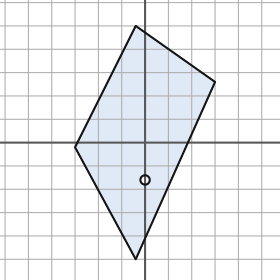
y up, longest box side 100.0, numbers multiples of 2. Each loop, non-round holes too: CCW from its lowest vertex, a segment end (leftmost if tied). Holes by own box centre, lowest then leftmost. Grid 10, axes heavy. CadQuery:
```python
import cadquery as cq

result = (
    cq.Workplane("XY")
    .moveTo(-4.0, -50.0)
    .lineTo(30.0, 26.0)
    .lineTo(-4.0, 50.0)
    .lineTo(-30.0, -2.0)
    .close()
    .moveTo(0.0, -16.0)
    .circle(2.0)
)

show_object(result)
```